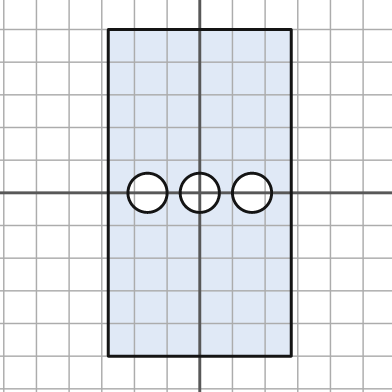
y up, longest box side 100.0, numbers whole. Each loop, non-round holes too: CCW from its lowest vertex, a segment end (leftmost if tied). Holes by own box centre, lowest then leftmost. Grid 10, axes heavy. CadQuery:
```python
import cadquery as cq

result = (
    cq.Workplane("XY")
    .moveTo(-28.0, -50.0)
    .lineTo(28.0, -50.0)
    .lineTo(28.0, 50.0)
    .lineTo(-28.0, 50.0)
    .close()
    .moveTo(-16.0, 0.0)
    .circle(6.0)
    .moveTo(0.0, 0.0)
    .circle(6.0)
    .moveTo(16.0, 0.0)
    .circle(6.0)
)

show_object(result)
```